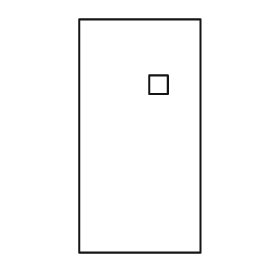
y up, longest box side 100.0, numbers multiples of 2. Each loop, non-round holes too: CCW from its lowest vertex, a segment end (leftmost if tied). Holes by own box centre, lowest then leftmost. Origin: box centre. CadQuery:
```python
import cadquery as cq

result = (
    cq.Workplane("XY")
    .moveTo(-26.0, -50.0)
    .lineTo(26.0, -50.0)
    .lineTo(26.0, 50.0)
    .lineTo(-26.0, 50.0)
    .close()
    .moveTo(4.0, 18.0)
    .lineTo(12.0, 18.0)
    .lineTo(12.0, 26.0)
    .lineTo(4.0, 26.0)
    .close()
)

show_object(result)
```